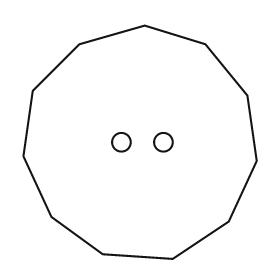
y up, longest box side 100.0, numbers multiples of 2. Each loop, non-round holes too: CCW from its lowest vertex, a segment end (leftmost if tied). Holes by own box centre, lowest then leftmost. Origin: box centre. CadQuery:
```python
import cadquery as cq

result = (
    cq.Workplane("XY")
    .moveTo(14.0, -50.0)
    .lineTo(38.0, -34.0)
    .lineTo(50.0, -8.0)
    .lineTo(46.0, 20.0)
    .lineTo(28.0, 42.0)
    .lineTo(2.0, 50.0)
    .lineTo(-26.0, 42.0)
    .lineTo(-46.0, 22.0)
    .lineTo(-50.0, -6.0)
    .lineTo(-38.0, -32.0)
    .lineTo(-16.0, -48.0)
    .close()
    .moveTo(-8.0, 0.0)
    .circle(4.0)
    .moveTo(10.0, 0.0)
    .circle(4.0)
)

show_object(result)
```